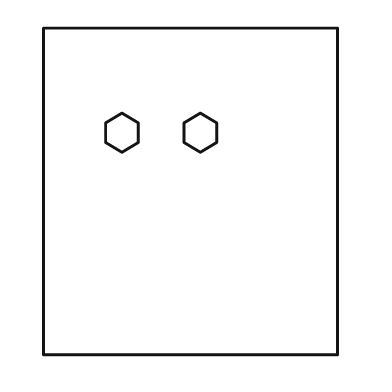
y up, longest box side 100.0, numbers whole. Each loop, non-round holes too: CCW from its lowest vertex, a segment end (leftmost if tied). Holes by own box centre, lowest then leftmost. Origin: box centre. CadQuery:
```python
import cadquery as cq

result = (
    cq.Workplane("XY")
    .moveTo(-45.0, -50.0)
    .lineTo(45.0, -50.0)
    .lineTo(45.0, 50.0)
    .lineTo(-45.0, 50.0)
    .close()
    .moveTo(-21.0, 12.0)
    .lineTo(-16.0, 15.0)
    .lineTo(-16.0, 21.0)
    .lineTo(-21.0, 24.0)
    .lineTo(-26.0, 21.0)
    .lineTo(-26.0, 15.0)
    .close()
    .moveTo(3.0, 12.0)
    .lineTo(8.0, 15.0)
    .lineTo(8.0, 21.0)
    .lineTo(3.0, 24.0)
    .lineTo(-2.0, 21.0)
    .lineTo(-2.0, 15.0)
    .close()
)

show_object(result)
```